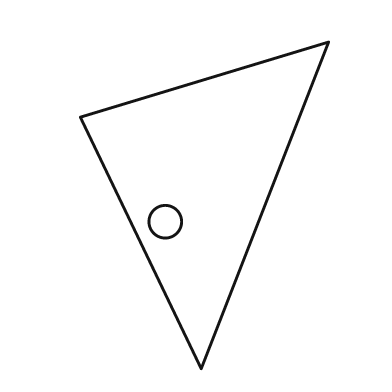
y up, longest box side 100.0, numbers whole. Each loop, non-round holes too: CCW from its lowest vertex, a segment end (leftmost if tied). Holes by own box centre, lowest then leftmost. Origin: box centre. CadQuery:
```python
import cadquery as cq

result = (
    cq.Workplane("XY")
    .moveTo(-1.0, -50.0)
    .lineTo(38.0, 50.0)
    .lineTo(-38.0, 27.0)
    .close()
    .moveTo(-12.0, -5.0)
    .circle(5.0)
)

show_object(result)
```